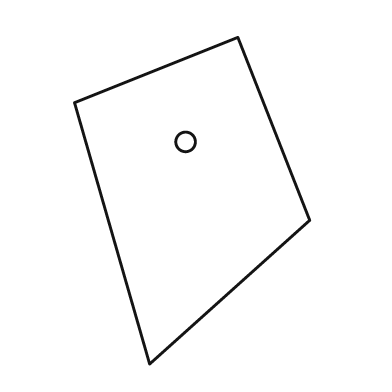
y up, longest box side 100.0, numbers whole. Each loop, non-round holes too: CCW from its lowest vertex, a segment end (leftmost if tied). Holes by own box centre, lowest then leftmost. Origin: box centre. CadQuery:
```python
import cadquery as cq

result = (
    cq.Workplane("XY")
    .moveTo(-13.0, -50.0)
    .lineTo(36.0, -6.0)
    .lineTo(14.0, 50.0)
    .lineTo(-36.0, 30.0)
    .close()
    .moveTo(-2.0, 18.0)
    .circle(3.0)
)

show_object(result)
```